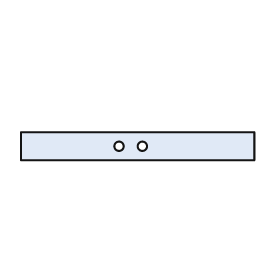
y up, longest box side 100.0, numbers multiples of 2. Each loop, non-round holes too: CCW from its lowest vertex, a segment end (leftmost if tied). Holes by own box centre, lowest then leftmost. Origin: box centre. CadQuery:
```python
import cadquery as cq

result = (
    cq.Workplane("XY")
    .moveTo(-50.0, -6.0)
    .lineTo(50.0, -6.0)
    .lineTo(50.0, 6.0)
    .lineTo(-50.0, 6.0)
    .close()
    .moveTo(-8.0, 0.0)
    .circle(2.0)
    .moveTo(2.0, 0.0)
    .circle(2.0)
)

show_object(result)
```